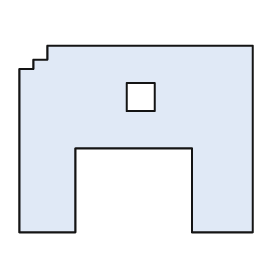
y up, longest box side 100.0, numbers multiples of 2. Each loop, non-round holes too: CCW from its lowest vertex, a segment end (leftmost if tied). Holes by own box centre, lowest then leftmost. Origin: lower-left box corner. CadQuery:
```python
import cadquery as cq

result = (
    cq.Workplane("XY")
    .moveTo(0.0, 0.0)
    .lineTo(24.0, 0.0)
    .lineTo(24.0, 36.0)
    .lineTo(74.0, 36.0)
    .lineTo(74.0, 0.0)
    .lineTo(100.0, 0.0)
    .lineTo(100.0, 80.0)
    .lineTo(12.0, 80.0)
    .lineTo(12.0, 74.0)
    .lineTo(6.0, 74.0)
    .lineTo(6.0, 70.0)
    .lineTo(0.0, 70.0)
    .close()
    .moveTo(46.0, 52.0)
    .lineTo(58.0, 52.0)
    .lineTo(58.0, 64.0)
    .lineTo(46.0, 64.0)
    .close()
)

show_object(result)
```